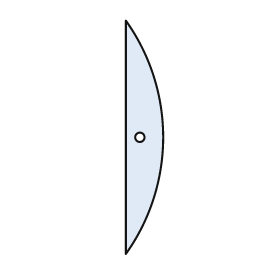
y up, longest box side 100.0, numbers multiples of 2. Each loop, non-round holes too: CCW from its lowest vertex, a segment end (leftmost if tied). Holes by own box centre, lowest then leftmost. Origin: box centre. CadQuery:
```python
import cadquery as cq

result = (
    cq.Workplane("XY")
    .moveTo(-8.0, -50.0)
    .threePointArc((8.0, 0.0), (-8.0, 50.0))
    .close()
    .moveTo(-2.0, 0.0)
    .circle(2.0)
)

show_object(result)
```